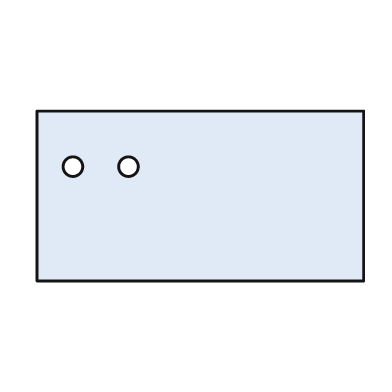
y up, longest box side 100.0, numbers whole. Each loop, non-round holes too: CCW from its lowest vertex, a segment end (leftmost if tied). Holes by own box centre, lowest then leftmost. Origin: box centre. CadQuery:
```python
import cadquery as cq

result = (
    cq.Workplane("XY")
    .moveTo(-50.0, -26.0)
    .lineTo(50.0, -26.0)
    .lineTo(50.0, 26.0)
    .lineTo(-50.0, 26.0)
    .close()
    .moveTo(-39.0, 9.0)
    .circle(3.0)
    .moveTo(-22.0, 9.0)
    .circle(3.0)
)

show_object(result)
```